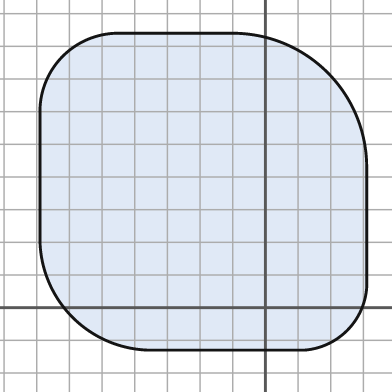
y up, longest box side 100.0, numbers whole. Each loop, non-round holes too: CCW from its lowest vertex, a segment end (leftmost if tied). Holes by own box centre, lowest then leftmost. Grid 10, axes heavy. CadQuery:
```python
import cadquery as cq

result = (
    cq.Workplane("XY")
    .moveTo(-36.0, -13.0)
    .lineTo(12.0, -13.0)
    .threePointArc((25.0, -7.0), (31.0, 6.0))
    .lineTo(31.0, 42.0)
    .threePointArc((19.0, 72.0), (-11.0, 84.0))
    .lineTo(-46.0, 84.0)
    .threePointArc((-62.0, 77.0), (-69.0, 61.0))
    .lineTo(-69.0, 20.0)
    .threePointArc((-59.0, -3.0), (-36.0, -13.0))
    .close()
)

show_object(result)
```